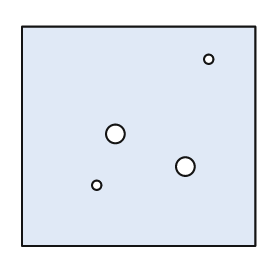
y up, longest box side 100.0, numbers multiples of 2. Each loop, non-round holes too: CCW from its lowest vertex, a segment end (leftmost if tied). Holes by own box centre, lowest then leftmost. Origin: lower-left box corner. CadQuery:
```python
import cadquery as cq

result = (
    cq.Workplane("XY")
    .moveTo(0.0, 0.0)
    .lineTo(100.0, 0.0)
    .lineTo(100.0, 94.0)
    .lineTo(0.0, 94.0)
    .close()
    .moveTo(32.0, 26.0)
    .circle(2.0)
    .moveTo(70.0, 34.0)
    .circle(4.0)
    .moveTo(40.0, 48.0)
    .circle(4.0)
    .moveTo(80.0, 80.0)
    .circle(2.0)
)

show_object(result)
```